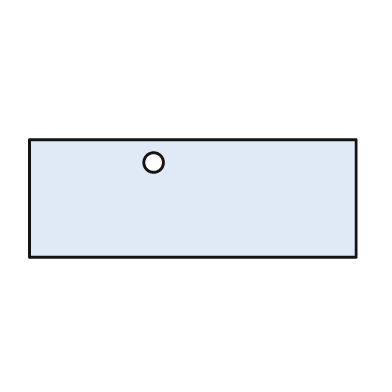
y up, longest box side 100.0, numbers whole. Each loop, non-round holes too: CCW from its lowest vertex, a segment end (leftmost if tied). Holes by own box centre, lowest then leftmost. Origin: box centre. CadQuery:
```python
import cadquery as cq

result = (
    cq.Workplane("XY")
    .moveTo(-50.0, -18.0)
    .lineTo(50.0, -18.0)
    .lineTo(50.0, 18.0)
    .lineTo(-50.0, 18.0)
    .close()
    .moveTo(-12.0, 11.0)
    .circle(3.0)
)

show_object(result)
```